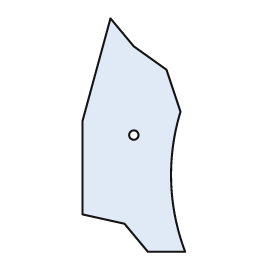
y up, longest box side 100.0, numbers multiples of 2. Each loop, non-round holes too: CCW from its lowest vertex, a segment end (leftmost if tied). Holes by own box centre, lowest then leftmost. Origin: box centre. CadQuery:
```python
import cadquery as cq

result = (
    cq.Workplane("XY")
    .moveTo(6.0, -50.0)
    .lineTo(22.0, -50.0)
    .threePointArc((16.0, -20.0), (20.0, 10.0))
    .lineTo(14.0, 28.0)
    .lineTo(0.0, 38.0)
    .lineTo(-10.0, 50.0)
    .lineTo(-22.0, 6.0)
    .lineTo(-22.0, -34.0)
    .lineTo(-4.0, -38.0)
    .close()
    .moveTo(0.0, 0.0)
    .circle(2.0)
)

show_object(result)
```